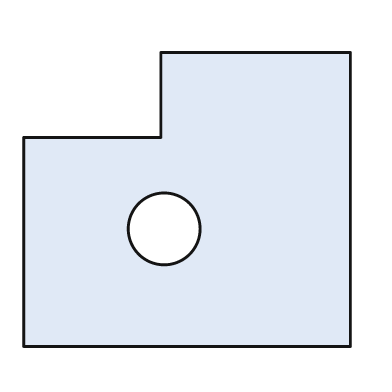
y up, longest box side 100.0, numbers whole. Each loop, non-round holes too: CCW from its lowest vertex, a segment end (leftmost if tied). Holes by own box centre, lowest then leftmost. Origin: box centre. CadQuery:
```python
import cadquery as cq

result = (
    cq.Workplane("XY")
    .moveTo(-50.0, -45.0)
    .lineTo(50.0, -45.0)
    .lineTo(50.0, 45.0)
    .lineTo(-8.0, 45.0)
    .lineTo(-8.0, 19.0)
    .lineTo(-50.0, 19.0)
    .close()
    .moveTo(-7.0, -9.0)
    .circle(11.0)
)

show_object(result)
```